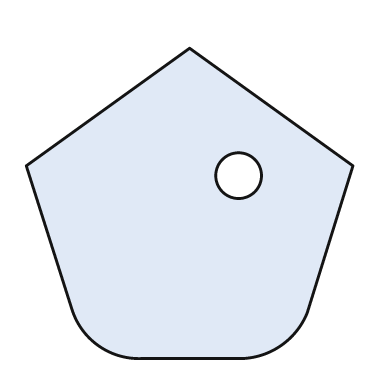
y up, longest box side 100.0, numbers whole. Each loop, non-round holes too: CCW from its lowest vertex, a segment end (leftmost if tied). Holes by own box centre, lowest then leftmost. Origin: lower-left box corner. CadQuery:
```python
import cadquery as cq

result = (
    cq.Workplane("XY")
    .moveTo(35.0, 0.0)
    .lineTo(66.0, 0.0)
    .threePointArc((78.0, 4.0), (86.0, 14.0))
    .lineTo(100.0, 59.0)
    .lineTo(50.0, 95.0)
    .lineTo(0.0, 59.0)
    .lineTo(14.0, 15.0)
    .threePointArc((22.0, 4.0), (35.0, 0.0))
    .close()
    .moveTo(65.0, 56.0)
    .circle(7.0)
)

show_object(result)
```